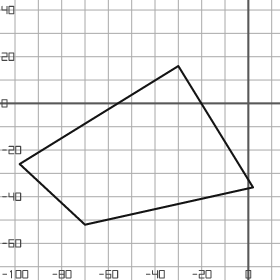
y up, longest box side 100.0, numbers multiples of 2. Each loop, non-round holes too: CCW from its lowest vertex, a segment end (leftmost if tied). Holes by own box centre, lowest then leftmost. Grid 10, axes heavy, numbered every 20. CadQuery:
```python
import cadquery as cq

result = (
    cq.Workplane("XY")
    .moveTo(-70.0, -52.0)
    .lineTo(2.0, -36.0)
    .lineTo(-30.0, 16.0)
    .lineTo(-98.0, -26.0)
    .close()
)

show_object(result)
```